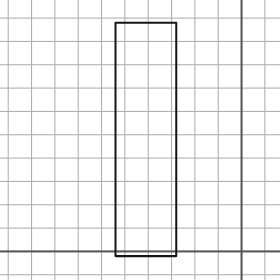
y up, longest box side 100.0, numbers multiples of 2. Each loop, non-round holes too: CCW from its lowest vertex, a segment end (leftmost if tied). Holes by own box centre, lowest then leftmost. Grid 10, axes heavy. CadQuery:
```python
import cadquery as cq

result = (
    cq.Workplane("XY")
    .moveTo(-54.0, -2.0)
    .lineTo(-28.0, -2.0)
    .lineTo(-28.0, 98.0)
    .lineTo(-54.0, 98.0)
    .close()
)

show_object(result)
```